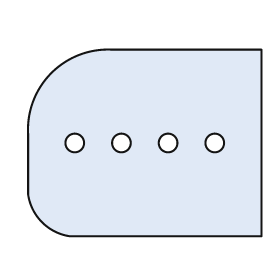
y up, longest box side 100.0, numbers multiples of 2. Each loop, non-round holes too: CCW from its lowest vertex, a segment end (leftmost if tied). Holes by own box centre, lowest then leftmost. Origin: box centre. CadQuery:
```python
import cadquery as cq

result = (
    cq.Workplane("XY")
    .moveTo(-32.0, -40.0)
    .lineTo(50.0, -40.0)
    .lineTo(50.0, 40.0)
    .lineTo(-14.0, 40.0)
    .threePointArc((-40.0, 30.0), (-50.0, 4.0))
    .lineTo(-50.0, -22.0)
    .threePointArc((-44.0, -34.0), (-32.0, -40.0))
    .close()
    .moveTo(-30.0, 0.0)
    .circle(4.0)
    .moveTo(-10.0, 0.0)
    .circle(4.0)
    .moveTo(10.0, 0.0)
    .circle(4.0)
    .moveTo(30.0, 0.0)
    .circle(4.0)
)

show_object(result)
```